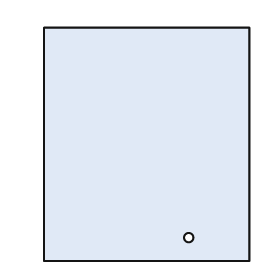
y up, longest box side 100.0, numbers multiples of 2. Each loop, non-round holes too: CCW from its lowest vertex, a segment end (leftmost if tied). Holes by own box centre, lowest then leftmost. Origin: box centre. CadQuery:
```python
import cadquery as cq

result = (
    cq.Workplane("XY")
    .moveTo(-44.0, -50.0)
    .lineTo(44.0, -50.0)
    .lineTo(44.0, 50.0)
    .lineTo(-44.0, 50.0)
    .close()
    .moveTo(18.0, -40.0)
    .circle(2.0)
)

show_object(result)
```